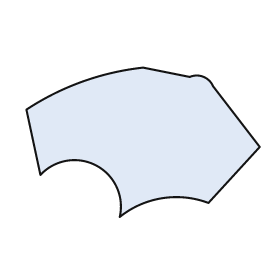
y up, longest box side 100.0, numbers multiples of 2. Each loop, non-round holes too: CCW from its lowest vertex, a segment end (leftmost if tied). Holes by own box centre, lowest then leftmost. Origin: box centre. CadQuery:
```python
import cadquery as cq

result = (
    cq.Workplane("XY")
    .moveTo(-10.0, -32.0)
    .threePointArc((8.0, -24.0), (28.0, -26.0))
    .lineTo(50.0, -2.0)
    .lineTo(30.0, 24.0)
    .threePointArc((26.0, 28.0), (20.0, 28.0))
    .lineTo(0.0, 32.0)
    .threePointArc((-26.0, 26.0), (-50.0, 14.0))
    .lineTo(-44.0, -14.0)
    .threePointArc((-20.0, -10.0), (-10.0, -32.0))
    .close()
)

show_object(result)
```